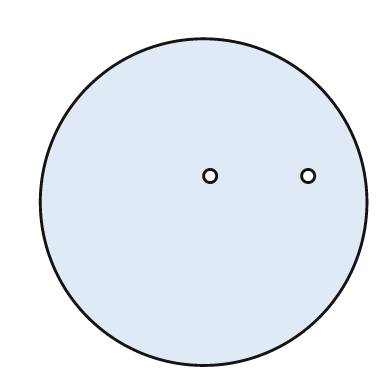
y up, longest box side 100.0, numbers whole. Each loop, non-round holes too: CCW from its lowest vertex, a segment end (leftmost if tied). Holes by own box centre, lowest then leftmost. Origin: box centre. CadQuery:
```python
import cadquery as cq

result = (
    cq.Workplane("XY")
    .moveTo(0.0, 0.0)
    .circle(50.0)
    .moveTo(2.0, 8.0)
    .circle(2.0)
    .moveTo(32.0, 8.0)
    .circle(2.0)
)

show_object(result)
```